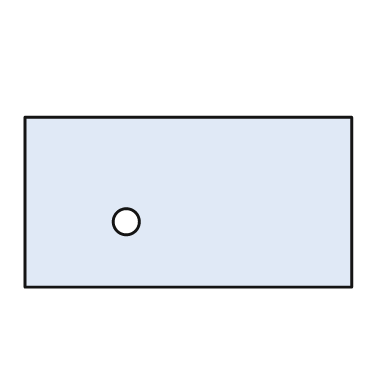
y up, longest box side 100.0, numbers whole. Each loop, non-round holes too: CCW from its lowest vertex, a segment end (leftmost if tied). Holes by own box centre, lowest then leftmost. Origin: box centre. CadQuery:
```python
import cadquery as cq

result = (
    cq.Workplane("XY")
    .moveTo(-50.0, -26.0)
    .lineTo(50.0, -26.0)
    .lineTo(50.0, 26.0)
    .lineTo(-50.0, 26.0)
    .close()
    .moveTo(-19.0, -6.0)
    .circle(4.0)
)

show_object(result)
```